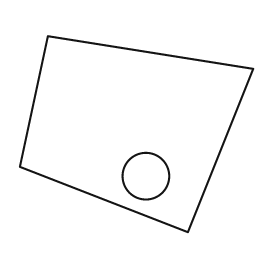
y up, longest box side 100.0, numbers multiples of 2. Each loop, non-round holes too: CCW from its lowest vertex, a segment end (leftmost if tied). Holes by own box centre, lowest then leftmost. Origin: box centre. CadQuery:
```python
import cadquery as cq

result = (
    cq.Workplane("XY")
    .moveTo(22.0, -42.0)
    .lineTo(50.0, 28.0)
    .lineTo(-38.0, 42.0)
    .lineTo(-50.0, -14.0)
    .close()
    .moveTo(4.0, -18.0)
    .circle(10.0)
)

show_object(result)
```